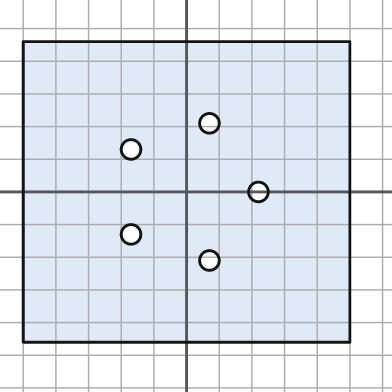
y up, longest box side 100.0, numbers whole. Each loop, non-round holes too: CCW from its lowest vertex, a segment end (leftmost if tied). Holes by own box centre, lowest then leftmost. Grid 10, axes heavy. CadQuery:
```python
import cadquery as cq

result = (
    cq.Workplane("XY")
    .moveTo(-50.0, -46.0)
    .lineTo(50.0, -46.0)
    .lineTo(50.0, 46.0)
    .lineTo(-50.0, 46.0)
    .close()
    .moveTo(7.0, -21.0)
    .circle(3.0)
    .moveTo(-17.0, -13.0)
    .circle(3.0)
    .moveTo(22.0, 0.0)
    .circle(3.0)
    .moveTo(-17.0, 13.0)
    .circle(3.0)
    .moveTo(7.0, 21.0)
    .circle(3.0)
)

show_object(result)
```